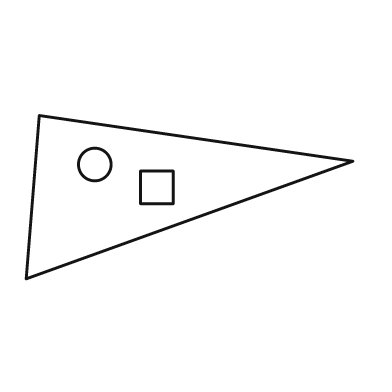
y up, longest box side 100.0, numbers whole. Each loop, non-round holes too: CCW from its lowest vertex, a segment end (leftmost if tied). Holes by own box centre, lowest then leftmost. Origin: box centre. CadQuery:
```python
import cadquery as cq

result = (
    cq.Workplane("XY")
    .moveTo(-50.0, -25.0)
    .lineTo(50.0, 11.0)
    .lineTo(-46.0, 25.0)
    .close()
    .moveTo(-15.0, -2.0)
    .lineTo(-5.0, -2.0)
    .lineTo(-5.0, 8.0)
    .lineTo(-15.0, 8.0)
    .close()
    .moveTo(-29.0, 10.0)
    .circle(5.0)
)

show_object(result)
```